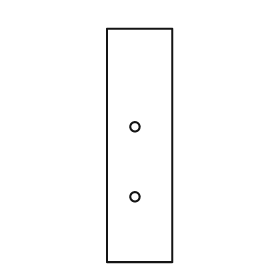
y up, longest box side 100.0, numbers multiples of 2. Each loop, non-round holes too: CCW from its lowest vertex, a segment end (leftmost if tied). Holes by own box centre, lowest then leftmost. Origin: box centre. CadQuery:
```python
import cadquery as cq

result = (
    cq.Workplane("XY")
    .moveTo(-14.0, -50.0)
    .lineTo(14.0, -50.0)
    .lineTo(14.0, 50.0)
    .lineTo(-14.0, 50.0)
    .close()
    .moveTo(-2.0, -22.0)
    .circle(2.0)
    .moveTo(-2.0, 8.0)
    .circle(2.0)
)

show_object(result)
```